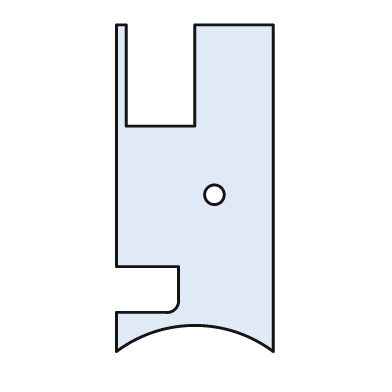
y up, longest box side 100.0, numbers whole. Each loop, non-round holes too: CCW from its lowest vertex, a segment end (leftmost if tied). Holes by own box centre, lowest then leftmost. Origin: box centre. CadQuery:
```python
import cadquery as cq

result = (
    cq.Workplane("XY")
    .moveTo(-24.0, -50.0)
    .threePointArc((0.0, -42.0), (24.0, -50.0))
    .lineTo(24.0, 50.0)
    .lineTo(0.0, 50.0)
    .lineTo(0.0, 19.0)
    .lineTo(-21.0, 19.0)
    .lineTo(-21.0, 50.0)
    .lineTo(-24.0, 50.0)
    .lineTo(-24.0, -24.0)
    .lineTo(-5.0, -24.0)
    .lineTo(-5.0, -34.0)
    .threePointArc((-6.0, -37.0), (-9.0, -38.0))
    .lineTo(-24.0, -38.0)
    .close()
    .moveTo(6.0, -2.0)
    .circle(3.0)
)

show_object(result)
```